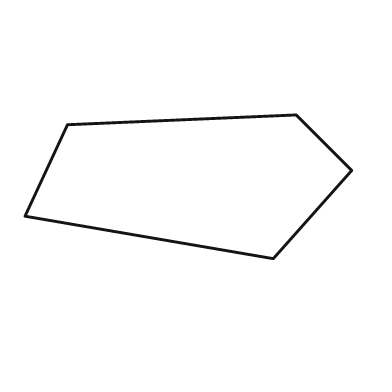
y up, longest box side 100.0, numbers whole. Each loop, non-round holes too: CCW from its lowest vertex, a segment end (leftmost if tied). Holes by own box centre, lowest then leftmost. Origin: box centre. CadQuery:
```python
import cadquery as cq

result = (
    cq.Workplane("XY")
    .moveTo(26.0, -22.0)
    .lineTo(50.0, 5.0)
    .lineTo(33.0, 22.0)
    .lineTo(-37.0, 19.0)
    .lineTo(-50.0, -9.0)
    .close()
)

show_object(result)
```